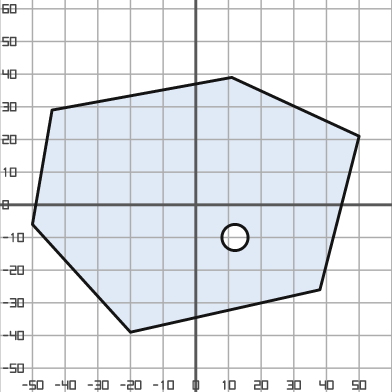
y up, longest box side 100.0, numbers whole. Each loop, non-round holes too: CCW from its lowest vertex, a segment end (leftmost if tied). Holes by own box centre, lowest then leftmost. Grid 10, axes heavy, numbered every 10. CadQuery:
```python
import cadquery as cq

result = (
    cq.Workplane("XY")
    .moveTo(-20.0, -39.0)
    .lineTo(38.0, -26.0)
    .lineTo(50.0, 21.0)
    .lineTo(11.0, 39.0)
    .lineTo(-44.0, 29.0)
    .lineTo(-50.0, -6.0)
    .close()
    .moveTo(12.0, -10.0)
    .circle(4.0)
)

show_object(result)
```